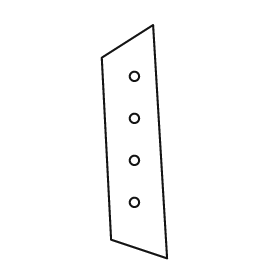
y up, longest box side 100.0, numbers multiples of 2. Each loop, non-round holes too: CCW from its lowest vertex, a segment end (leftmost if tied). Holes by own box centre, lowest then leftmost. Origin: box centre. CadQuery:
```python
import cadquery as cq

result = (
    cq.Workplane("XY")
    .moveTo(14.0, -50.0)
    .lineTo(8.0, 50.0)
    .lineTo(-14.0, 36.0)
    .lineTo(-10.0, -42.0)
    .close()
    .moveTo(0.0, -26.0)
    .circle(2.0)
    .moveTo(0.0, -8.0)
    .circle(2.0)
    .moveTo(0.0, 10.0)
    .circle(2.0)
    .moveTo(0.0, 28.0)
    .circle(2.0)
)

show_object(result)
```